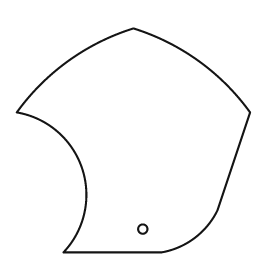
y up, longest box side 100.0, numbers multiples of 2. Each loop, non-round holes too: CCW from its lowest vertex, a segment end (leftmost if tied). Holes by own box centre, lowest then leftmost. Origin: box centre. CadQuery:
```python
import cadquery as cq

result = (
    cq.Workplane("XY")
    .moveTo(-30.0, -48.0)
    .lineTo(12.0, -48.0)
    .threePointArc((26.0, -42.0), (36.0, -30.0))
    .lineTo(50.0, 12.0)
    .threePointArc((28.0, 34.0), (0.0, 48.0))
    .threePointArc((-28.0, 34.0), (-50.0, 12.0))
    .threePointArc((-22.0, -12.0), (-30.0, -48.0))
    .close()
    .moveTo(4.0, -38.0)
    .circle(2.0)
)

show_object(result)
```